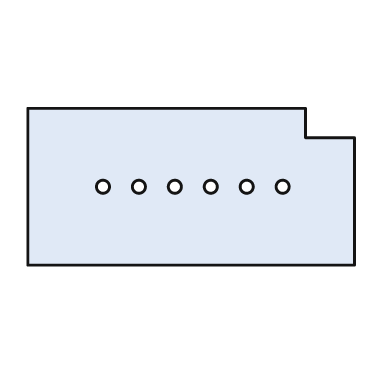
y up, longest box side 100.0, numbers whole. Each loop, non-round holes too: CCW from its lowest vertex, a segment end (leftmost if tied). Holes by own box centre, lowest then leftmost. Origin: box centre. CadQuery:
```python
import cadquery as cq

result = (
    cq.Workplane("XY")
    .moveTo(-50.0, -24.0)
    .lineTo(50.0, -24.0)
    .lineTo(50.0, 15.0)
    .lineTo(35.0, 15.0)
    .lineTo(35.0, 24.0)
    .lineTo(-50.0, 24.0)
    .close()
    .moveTo(-27.0, 0.0)
    .circle(2.0)
    .moveTo(-16.0, 0.0)
    .circle(2.0)
    .moveTo(-5.0, 0.0)
    .circle(2.0)
    .moveTo(6.0, 0.0)
    .circle(2.0)
    .moveTo(17.0, 0.0)
    .circle(2.0)
    .moveTo(28.0, 0.0)
    .circle(2.0)
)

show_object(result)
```